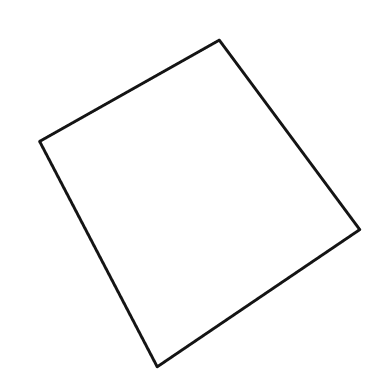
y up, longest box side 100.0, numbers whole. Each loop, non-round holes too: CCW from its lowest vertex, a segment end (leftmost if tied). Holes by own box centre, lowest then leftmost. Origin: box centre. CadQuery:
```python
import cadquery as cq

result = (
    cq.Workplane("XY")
    .moveTo(-13.0, -50.0)
    .lineTo(49.0, -8.0)
    .lineTo(6.0, 50.0)
    .lineTo(-49.0, 19.0)
    .close()
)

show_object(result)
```